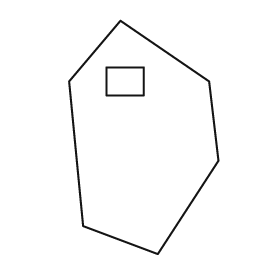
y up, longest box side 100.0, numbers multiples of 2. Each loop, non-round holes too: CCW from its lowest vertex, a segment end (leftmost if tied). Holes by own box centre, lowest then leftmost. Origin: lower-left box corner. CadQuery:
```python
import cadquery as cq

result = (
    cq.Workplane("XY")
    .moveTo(38.0, 0.0)
    .lineTo(64.0, 40.0)
    .lineTo(60.0, 74.0)
    .lineTo(22.0, 100.0)
    .lineTo(0.0, 74.0)
    .lineTo(6.0, 12.0)
    .close()
    .moveTo(16.0, 68.0)
    .lineTo(32.0, 68.0)
    .lineTo(32.0, 80.0)
    .lineTo(16.0, 80.0)
    .close()
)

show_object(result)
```